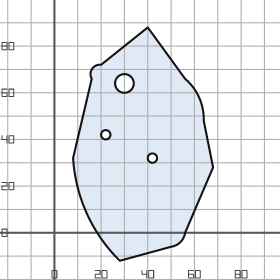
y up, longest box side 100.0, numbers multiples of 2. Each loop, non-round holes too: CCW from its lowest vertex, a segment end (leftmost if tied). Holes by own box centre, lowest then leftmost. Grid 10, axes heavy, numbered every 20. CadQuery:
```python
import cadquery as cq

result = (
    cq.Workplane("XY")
    .moveTo(28.0, -12.0)
    .lineTo(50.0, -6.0)
    .threePointArc((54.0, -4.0), (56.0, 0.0))
    .lineTo(68.0, 28.0)
    .lineTo(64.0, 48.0)
    .threePointArc((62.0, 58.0), (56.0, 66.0))
    .lineTo(40.0, 88.0)
    .lineTo(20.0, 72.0)
    .threePointArc((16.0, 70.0), (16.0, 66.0))
    .lineTo(8.0, 32.0)
    .threePointArc((14.0, 8.0), (28.0, -12.0))
    .close()
    .moveTo(42.0, 32.0)
    .circle(2.0)
    .moveTo(22.0, 42.0)
    .circle(2.0)
    .moveTo(30.0, 64.0)
    .circle(4.0)
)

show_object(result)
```